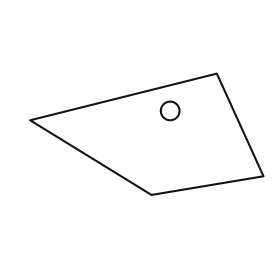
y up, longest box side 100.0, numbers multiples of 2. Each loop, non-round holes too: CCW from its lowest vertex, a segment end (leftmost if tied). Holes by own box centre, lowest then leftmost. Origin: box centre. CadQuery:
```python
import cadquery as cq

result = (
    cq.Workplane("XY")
    .moveTo(2.0, -26.0)
    .lineTo(50.0, -18.0)
    .lineTo(30.0, 26.0)
    .lineTo(-50.0, 6.0)
    .close()
    .moveTo(10.0, 10.0)
    .circle(4.0)
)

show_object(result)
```